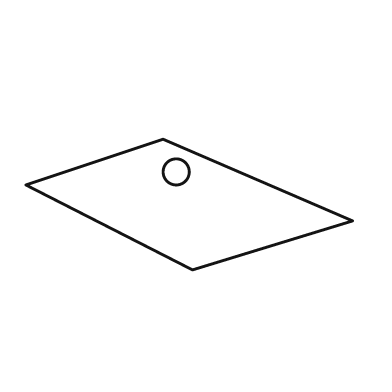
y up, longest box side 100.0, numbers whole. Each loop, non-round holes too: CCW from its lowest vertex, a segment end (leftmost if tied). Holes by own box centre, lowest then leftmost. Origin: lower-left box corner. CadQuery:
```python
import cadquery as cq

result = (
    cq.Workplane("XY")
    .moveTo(51.0, 0.0)
    .lineTo(100.0, 15.0)
    .lineTo(42.0, 40.0)
    .lineTo(0.0, 26.0)
    .close()
    .moveTo(46.0, 30.0)
    .circle(4.0)
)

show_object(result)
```